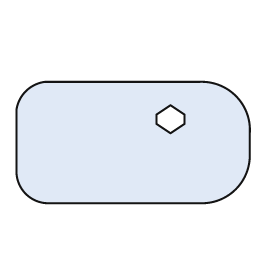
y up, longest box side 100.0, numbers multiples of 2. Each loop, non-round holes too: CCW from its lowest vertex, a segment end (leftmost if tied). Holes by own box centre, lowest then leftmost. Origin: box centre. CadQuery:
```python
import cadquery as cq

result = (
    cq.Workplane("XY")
    .moveTo(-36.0, -26.0)
    .lineTo(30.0, -26.0)
    .threePointArc((44.0, -20.0), (50.0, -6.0))
    .lineTo(50.0, 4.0)
    .threePointArc((44.0, 20.0), (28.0, 26.0))
    .lineTo(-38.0, 26.0)
    .threePointArc((-46.0, 22.0), (-50.0, 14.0))
    .lineTo(-50.0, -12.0)
    .threePointArc((-46.0, -22.0), (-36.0, -26.0))
    .close()
    .moveTo(16.0, 4.0)
    .lineTo(22.0, 8.0)
    .lineTo(22.0, 12.0)
    .lineTo(16.0, 16.0)
    .lineTo(10.0, 12.0)
    .lineTo(10.0, 8.0)
    .close()
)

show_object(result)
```